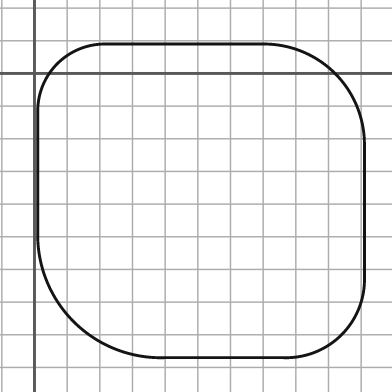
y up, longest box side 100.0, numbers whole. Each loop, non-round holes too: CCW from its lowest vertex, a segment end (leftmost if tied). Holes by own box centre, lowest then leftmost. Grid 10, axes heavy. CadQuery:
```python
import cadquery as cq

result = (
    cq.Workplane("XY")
    .moveTo(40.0, -87.0)
    .lineTo(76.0, -87.0)
    .threePointArc((94.0, -80.0), (101.0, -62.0))
    .lineTo(101.0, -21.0)
    .threePointArc((92.0, 0.0), (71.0, 9.0))
    .lineTo(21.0, 9.0)
    .threePointArc((7.0, 3.0), (1.0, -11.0))
    .lineTo(1.0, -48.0)
    .threePointArc((12.0, -76.0), (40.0, -87.0))
    .close()
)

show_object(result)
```